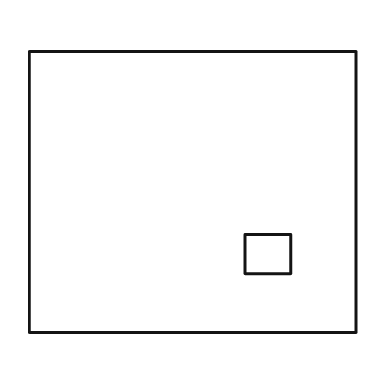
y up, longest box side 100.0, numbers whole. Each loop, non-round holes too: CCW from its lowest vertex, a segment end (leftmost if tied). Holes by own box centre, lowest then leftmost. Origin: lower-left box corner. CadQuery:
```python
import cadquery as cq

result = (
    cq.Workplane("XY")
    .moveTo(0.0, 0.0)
    .lineTo(100.0, 0.0)
    .lineTo(100.0, 86.0)
    .lineTo(0.0, 86.0)
    .close()
    .moveTo(66.0, 18.0)
    .lineTo(80.0, 18.0)
    .lineTo(80.0, 30.0)
    .lineTo(66.0, 30.0)
    .close()
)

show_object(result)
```